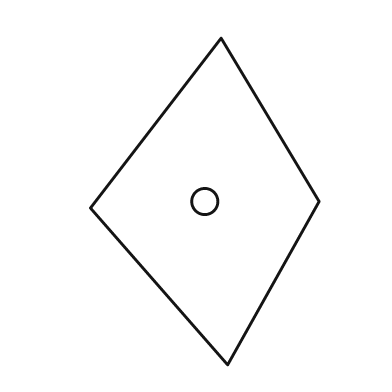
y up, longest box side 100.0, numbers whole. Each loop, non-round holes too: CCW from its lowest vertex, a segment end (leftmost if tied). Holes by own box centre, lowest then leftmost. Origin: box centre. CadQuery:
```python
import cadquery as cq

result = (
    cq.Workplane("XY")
    .moveTo(7.0, -50.0)
    .lineTo(35.0, 0.0)
    .lineTo(5.0, 50.0)
    .lineTo(-35.0, -2.0)
    .close()
    .moveTo(0.0, 0.0)
    .circle(4.0)
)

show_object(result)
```